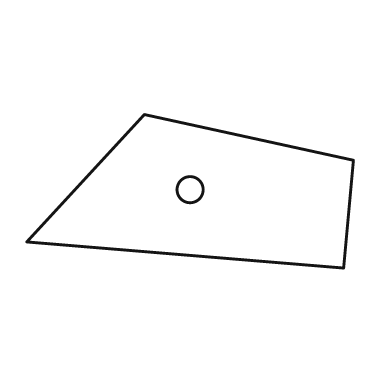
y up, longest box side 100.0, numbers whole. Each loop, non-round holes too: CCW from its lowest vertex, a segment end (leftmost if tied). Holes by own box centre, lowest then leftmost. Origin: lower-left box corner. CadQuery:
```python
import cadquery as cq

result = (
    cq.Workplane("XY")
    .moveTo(97.0, 0.0)
    .lineTo(100.0, 33.0)
    .lineTo(36.0, 47.0)
    .lineTo(0.0, 8.0)
    .close()
    .moveTo(50.0, 24.0)
    .circle(4.0)
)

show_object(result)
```